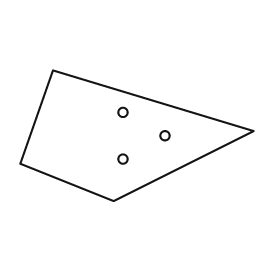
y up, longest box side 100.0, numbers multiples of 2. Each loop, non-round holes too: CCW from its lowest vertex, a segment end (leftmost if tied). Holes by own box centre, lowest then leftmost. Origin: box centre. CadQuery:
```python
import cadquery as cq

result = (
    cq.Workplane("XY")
    .moveTo(-10.0, -28.0)
    .lineTo(50.0, 2.0)
    .lineTo(-36.0, 28.0)
    .lineTo(-50.0, -12.0)
    .close()
    .moveTo(-6.0, -10.0)
    .circle(2.0)
    .moveTo(12.0, 0.0)
    .circle(2.0)
    .moveTo(-6.0, 10.0)
    .circle(2.0)
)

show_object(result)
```